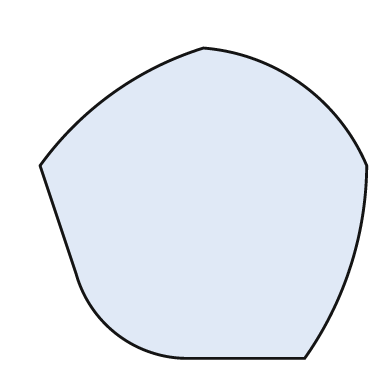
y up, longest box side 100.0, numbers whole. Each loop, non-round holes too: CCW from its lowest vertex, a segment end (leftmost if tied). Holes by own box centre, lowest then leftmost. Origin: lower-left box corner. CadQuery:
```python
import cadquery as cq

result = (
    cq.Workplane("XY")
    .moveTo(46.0, 0.0)
    .lineTo(81.0, 0.0)
    .threePointArc((95.0, 28.0), (100.0, 59.0))
    .threePointArc((80.0, 84.0), (50.0, 95.0))
    .threePointArc((22.0, 81.0), (0.0, 59.0))
    .lineTo(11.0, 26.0)
    .threePointArc((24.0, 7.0), (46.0, 0.0))
    .close()
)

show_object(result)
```